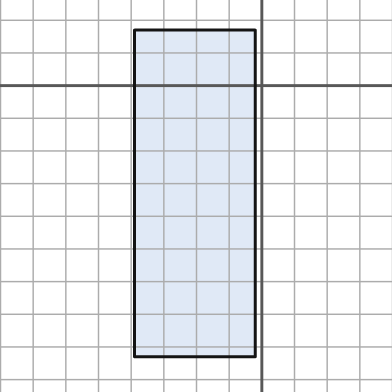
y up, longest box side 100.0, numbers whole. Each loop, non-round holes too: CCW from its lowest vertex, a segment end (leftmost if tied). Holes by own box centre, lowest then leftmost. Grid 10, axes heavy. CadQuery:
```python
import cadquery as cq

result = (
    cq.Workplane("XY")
    .moveTo(-39.0, -83.0)
    .lineTo(-2.0, -83.0)
    .lineTo(-2.0, 17.0)
    .lineTo(-39.0, 17.0)
    .close()
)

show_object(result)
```